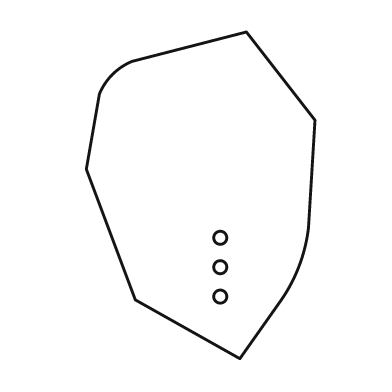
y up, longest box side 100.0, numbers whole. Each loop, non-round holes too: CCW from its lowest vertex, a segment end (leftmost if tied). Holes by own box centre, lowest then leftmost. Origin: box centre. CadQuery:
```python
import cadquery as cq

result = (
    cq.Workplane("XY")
    .moveTo(12.0, -50.0)
    .lineTo(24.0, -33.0)
    .threePointArc((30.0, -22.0), (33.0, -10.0))
    .lineTo(35.0, 23.0)
    .lineTo(14.0, 50.0)
    .lineTo(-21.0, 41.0)
    .threePointArc((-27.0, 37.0), (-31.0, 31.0))
    .lineTo(-35.0, 8.0)
    .lineTo(-20.0, -32.0)
    .close()
    .moveTo(6.0, -31.0)
    .circle(2.0)
    .moveTo(6.0, -22.0)
    .circle(2.0)
    .moveTo(6.0, -13.0)
    .circle(2.0)
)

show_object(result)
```